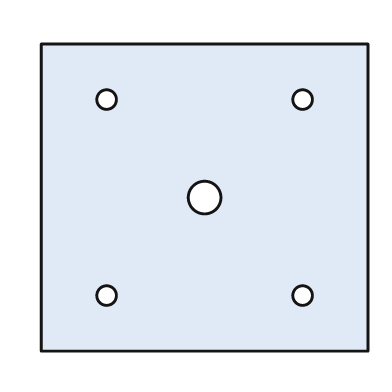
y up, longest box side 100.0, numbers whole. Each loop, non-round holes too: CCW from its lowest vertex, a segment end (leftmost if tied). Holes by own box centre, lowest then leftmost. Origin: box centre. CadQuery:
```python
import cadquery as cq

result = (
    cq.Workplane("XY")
    .moveTo(-50.0, -47.0)
    .lineTo(50.0, -47.0)
    .lineTo(50.0, 47.0)
    .lineTo(-50.0, 47.0)
    .close()
    .moveTo(-30.0, -30.0)
    .circle(3.0)
    .moveTo(30.0, -30.0)
    .circle(3.0)
    .moveTo(0.0, 0.0)
    .circle(5.0)
    .moveTo(-30.0, 30.0)
    .circle(3.0)
    .moveTo(30.0, 30.0)
    .circle(3.0)
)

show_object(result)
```